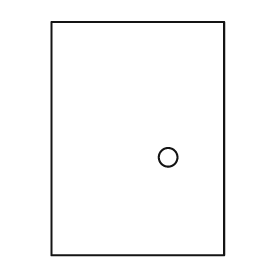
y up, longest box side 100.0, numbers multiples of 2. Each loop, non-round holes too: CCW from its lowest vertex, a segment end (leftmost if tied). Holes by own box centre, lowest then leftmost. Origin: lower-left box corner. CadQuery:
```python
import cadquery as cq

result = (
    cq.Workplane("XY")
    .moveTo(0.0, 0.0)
    .lineTo(74.0, 0.0)
    .lineTo(74.0, 100.0)
    .lineTo(0.0, 100.0)
    .close()
    .moveTo(50.0, 42.0)
    .circle(4.0)
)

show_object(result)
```